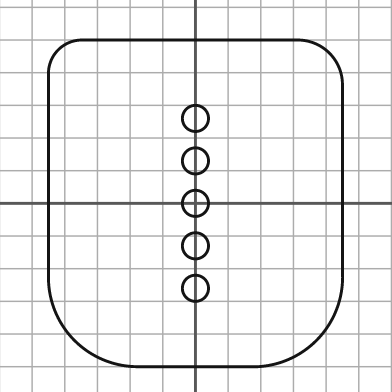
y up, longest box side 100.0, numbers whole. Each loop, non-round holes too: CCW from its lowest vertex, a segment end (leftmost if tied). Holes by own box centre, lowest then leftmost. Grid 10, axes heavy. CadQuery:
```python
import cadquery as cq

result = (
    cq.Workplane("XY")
    .moveTo(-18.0, -50.0)
    .lineTo(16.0, -50.0)
    .threePointArc((37.0, -42.0), (45.0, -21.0))
    .lineTo(45.0, 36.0)
    .threePointArc((41.0, 46.0), (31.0, 50.0))
    .lineTo(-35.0, 50.0)
    .threePointArc((-42.0, 47.0), (-45.0, 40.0))
    .lineTo(-45.0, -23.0)
    .threePointArc((-37.0, -42.0), (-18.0, -50.0))
    .close()
    .moveTo(0.0, -26.0)
    .circle(4.0)
    .moveTo(0.0, -13.0)
    .circle(4.0)
    .moveTo(0.0, 0.0)
    .circle(4.0)
    .moveTo(0.0, 13.0)
    .circle(4.0)
    .moveTo(0.0, 26.0)
    .circle(4.0)
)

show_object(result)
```